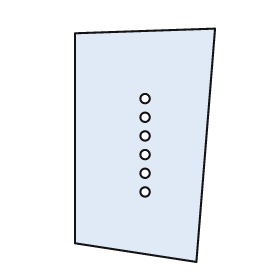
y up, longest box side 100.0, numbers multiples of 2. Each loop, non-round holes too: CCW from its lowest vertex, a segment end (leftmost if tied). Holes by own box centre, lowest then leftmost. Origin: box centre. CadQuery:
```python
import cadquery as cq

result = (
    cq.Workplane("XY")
    .moveTo(22.0, -50.0)
    .lineTo(30.0, 50.0)
    .lineTo(-30.0, 48.0)
    .lineTo(-30.0, -42.0)
    .close()
    .moveTo(0.0, -20.0)
    .circle(2.0)
    .moveTo(0.0, -12.0)
    .circle(2.0)
    .moveTo(0.0, -4.0)
    .circle(2.0)
    .moveTo(0.0, 4.0)
    .circle(2.0)
    .moveTo(0.0, 12.0)
    .circle(2.0)
    .moveTo(0.0, 20.0)
    .circle(2.0)
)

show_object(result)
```